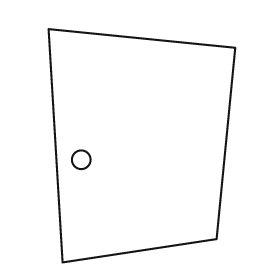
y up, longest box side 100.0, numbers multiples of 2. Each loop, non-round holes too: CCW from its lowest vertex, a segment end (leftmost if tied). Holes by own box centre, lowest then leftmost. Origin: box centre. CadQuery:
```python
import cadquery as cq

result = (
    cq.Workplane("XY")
    .moveTo(-34.0, -50.0)
    .lineTo(32.0, -40.0)
    .lineTo(40.0, 42.0)
    .lineTo(-40.0, 50.0)
    .close()
    .moveTo(-26.0, -6.0)
    .circle(4.0)
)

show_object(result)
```